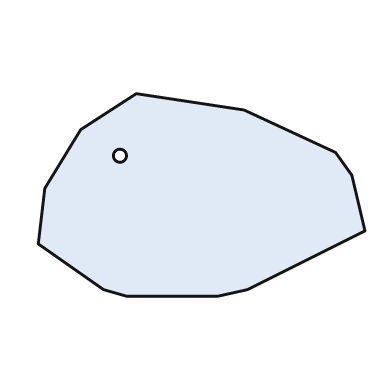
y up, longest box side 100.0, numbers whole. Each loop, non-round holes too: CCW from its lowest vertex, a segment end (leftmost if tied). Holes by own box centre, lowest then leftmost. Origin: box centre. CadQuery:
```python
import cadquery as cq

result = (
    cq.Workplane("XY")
    .moveTo(-23.0, -31.0)
    .lineTo(5.0, -31.0)
    .lineTo(14.0, -29.0)
    .lineTo(50.0, -11.0)
    .lineTo(46.0, 6.0)
    .lineTo(41.0, 13.0)
    .lineTo(13.0, 26.0)
    .lineTo(-20.0, 31.0)
    .lineTo(-37.0, 20.0)
    .lineTo(-48.0, 2.0)
    .lineTo(-50.0, -15.0)
    .lineTo(-30.0, -29.0)
    .close()
    .moveTo(-25.0, 12.0)
    .circle(2.0)
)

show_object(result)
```